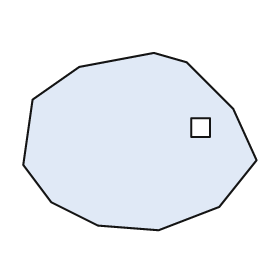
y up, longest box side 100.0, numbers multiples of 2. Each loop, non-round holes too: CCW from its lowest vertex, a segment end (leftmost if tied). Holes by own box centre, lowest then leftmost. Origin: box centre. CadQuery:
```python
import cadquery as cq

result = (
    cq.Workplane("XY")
    .moveTo(8.0, -38.0)
    .lineTo(34.0, -28.0)
    .lineTo(50.0, -8.0)
    .lineTo(40.0, 14.0)
    .lineTo(20.0, 34.0)
    .lineTo(6.0, 38.0)
    .lineTo(-26.0, 32.0)
    .lineTo(-46.0, 18.0)
    .lineTo(-50.0, -10.0)
    .lineTo(-38.0, -26.0)
    .lineTo(-18.0, -36.0)
    .close()
    .moveTo(22.0, 2.0)
    .lineTo(30.0, 2.0)
    .lineTo(30.0, 10.0)
    .lineTo(22.0, 10.0)
    .close()
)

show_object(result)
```